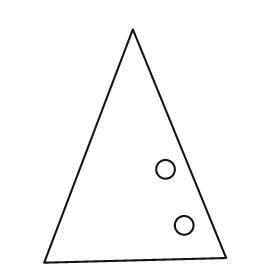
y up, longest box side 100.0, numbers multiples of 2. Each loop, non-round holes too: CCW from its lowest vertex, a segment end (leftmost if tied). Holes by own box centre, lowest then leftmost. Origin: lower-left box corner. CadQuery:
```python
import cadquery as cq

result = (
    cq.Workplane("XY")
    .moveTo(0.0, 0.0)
    .lineTo(78.0, 2.0)
    .lineTo(38.0, 100.0)
    .close()
    .moveTo(60.0, 16.0)
    .circle(4.0)
    .moveTo(52.0, 40.0)
    .circle(4.0)
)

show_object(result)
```